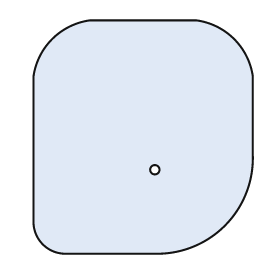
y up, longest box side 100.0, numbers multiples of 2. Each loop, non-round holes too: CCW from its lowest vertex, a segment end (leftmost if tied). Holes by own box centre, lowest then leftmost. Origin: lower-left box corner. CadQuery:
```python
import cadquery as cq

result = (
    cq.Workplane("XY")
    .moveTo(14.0, 0.0)
    .lineTo(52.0, 0.0)
    .threePointArc((82.0, 12.0), (94.0, 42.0))
    .lineTo(94.0, 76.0)
    .threePointArc((86.0, 92.0), (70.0, 100.0))
    .lineTo(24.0, 100.0)
    .threePointArc((8.0, 92.0), (0.0, 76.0))
    .lineTo(0.0, 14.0)
    .threePointArc((4.0, 4.0), (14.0, 0.0))
    .close()
    .moveTo(52.0, 36.0)
    .circle(2.0)
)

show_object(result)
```